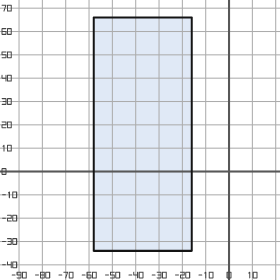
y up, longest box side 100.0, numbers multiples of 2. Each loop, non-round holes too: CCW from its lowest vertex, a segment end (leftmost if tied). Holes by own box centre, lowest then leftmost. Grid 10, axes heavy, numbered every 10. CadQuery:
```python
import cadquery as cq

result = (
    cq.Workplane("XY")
    .moveTo(-58.0, -34.0)
    .lineTo(-16.0, -34.0)
    .lineTo(-16.0, 66.0)
    .lineTo(-58.0, 66.0)
    .close()
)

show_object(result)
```